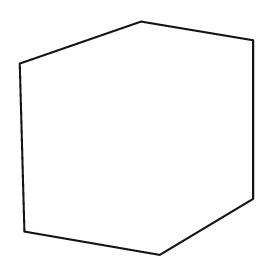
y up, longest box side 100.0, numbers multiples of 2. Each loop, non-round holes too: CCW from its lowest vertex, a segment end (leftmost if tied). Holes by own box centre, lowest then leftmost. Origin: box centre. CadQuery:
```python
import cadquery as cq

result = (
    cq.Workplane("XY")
    .moveTo(10.0, -50.0)
    .lineTo(50.0, -26.0)
    .lineTo(50.0, 42.0)
    .lineTo(2.0, 50.0)
    .lineTo(-50.0, 32.0)
    .lineTo(-48.0, -40.0)
    .close()
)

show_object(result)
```